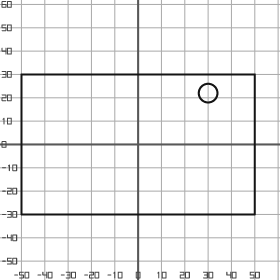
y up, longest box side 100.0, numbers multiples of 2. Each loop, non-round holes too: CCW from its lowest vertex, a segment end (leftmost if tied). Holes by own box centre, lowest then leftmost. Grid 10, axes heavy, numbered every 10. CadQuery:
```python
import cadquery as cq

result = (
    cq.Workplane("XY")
    .moveTo(-50.0, -30.0)
    .lineTo(50.0, -30.0)
    .lineTo(50.0, 30.0)
    .lineTo(-50.0, 30.0)
    .close()
    .moveTo(30.0, 22.0)
    .circle(4.0)
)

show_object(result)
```